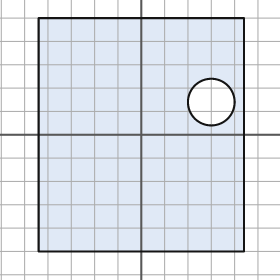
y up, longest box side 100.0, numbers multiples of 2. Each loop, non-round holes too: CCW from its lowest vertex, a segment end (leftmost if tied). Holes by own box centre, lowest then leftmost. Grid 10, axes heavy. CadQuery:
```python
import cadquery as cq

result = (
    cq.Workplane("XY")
    .moveTo(-44.0, -50.0)
    .lineTo(44.0, -50.0)
    .lineTo(44.0, 50.0)
    .lineTo(-44.0, 50.0)
    .close()
    .moveTo(30.0, 14.0)
    .circle(10.0)
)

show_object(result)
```